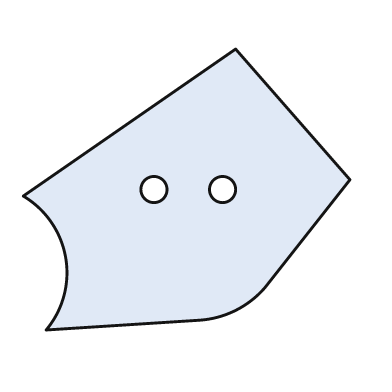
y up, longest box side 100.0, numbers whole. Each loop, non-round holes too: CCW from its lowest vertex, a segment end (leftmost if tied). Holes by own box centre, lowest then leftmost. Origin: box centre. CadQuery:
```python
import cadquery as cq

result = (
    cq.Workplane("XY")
    .moveTo(-43.0, -43.0)
    .lineTo(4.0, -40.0)
    .threePointArc((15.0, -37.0), (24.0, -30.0))
    .lineTo(50.0, 3.0)
    .lineTo(15.0, 43.0)
    .lineTo(-50.0, -2.0)
    .threePointArc((-37.0, -21.0), (-43.0, -43.0))
    .close()
    .moveTo(-10.0, 0.0)
    .circle(4.0)
    .moveTo(11.0, 0.0)
    .circle(4.0)
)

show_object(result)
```